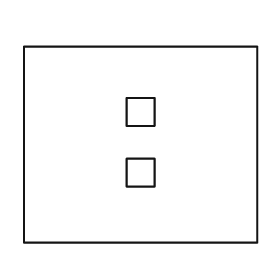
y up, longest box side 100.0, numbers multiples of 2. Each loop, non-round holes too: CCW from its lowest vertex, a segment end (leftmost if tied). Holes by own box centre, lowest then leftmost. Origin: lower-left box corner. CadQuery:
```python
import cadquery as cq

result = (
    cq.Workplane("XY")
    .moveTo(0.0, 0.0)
    .lineTo(100.0, 0.0)
    .lineTo(100.0, 84.0)
    .lineTo(0.0, 84.0)
    .close()
    .moveTo(44.0, 24.0)
    .lineTo(56.0, 24.0)
    .lineTo(56.0, 36.0)
    .lineTo(44.0, 36.0)
    .close()
    .moveTo(44.0, 50.0)
    .lineTo(56.0, 50.0)
    .lineTo(56.0, 62.0)
    .lineTo(44.0, 62.0)
    .close()
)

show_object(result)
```